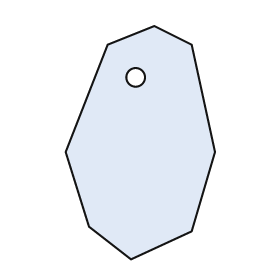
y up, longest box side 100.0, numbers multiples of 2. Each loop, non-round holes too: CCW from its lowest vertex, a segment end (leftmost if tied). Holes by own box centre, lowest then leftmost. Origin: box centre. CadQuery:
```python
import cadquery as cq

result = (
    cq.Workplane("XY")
    .moveTo(-4.0, -50.0)
    .lineTo(22.0, -38.0)
    .lineTo(32.0, -4.0)
    .lineTo(22.0, 42.0)
    .lineTo(6.0, 50.0)
    .lineTo(-14.0, 42.0)
    .lineTo(-32.0, -4.0)
    .lineTo(-22.0, -36.0)
    .close()
    .moveTo(-2.0, 28.0)
    .circle(4.0)
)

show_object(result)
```